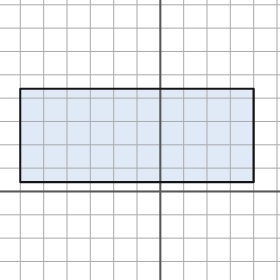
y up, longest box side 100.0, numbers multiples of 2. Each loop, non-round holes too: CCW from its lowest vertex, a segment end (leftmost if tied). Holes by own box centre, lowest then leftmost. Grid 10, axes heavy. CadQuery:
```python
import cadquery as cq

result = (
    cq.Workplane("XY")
    .moveTo(-60.0, 4.0)
    .lineTo(40.0, 4.0)
    .lineTo(40.0, 44.0)
    .lineTo(-60.0, 44.0)
    .close()
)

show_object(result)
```